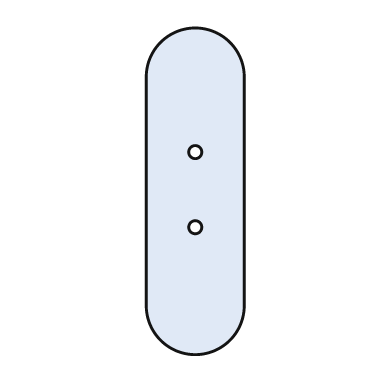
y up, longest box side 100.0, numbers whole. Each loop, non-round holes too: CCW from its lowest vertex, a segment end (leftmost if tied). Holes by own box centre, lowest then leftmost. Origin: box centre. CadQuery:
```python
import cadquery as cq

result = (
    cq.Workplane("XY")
    .moveTo(-15.0, -35.0)
    .threePointArc((0.0, -50.0), (15.0, -35.0))
    .lineTo(15.0, 35.0)
    .threePointArc((0.0, 50.0), (-15.0, 35.0))
    .close()
    .moveTo(0.0, -11.0)
    .circle(2.0)
    .moveTo(0.0, 12.0)
    .circle(2.0)
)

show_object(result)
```